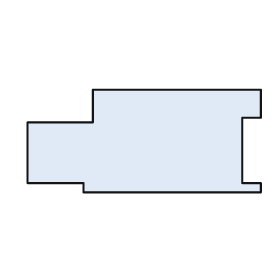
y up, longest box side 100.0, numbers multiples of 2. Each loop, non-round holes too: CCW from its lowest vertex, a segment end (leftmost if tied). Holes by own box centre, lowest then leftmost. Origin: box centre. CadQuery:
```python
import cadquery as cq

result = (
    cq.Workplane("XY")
    .moveTo(-26.0, -22.0)
    .lineTo(50.0, -22.0)
    .lineTo(50.0, -18.0)
    .lineTo(42.0, -18.0)
    .lineTo(42.0, 10.0)
    .lineTo(50.0, 10.0)
    .lineTo(50.0, 22.0)
    .lineTo(-22.0, 22.0)
    .lineTo(-22.0, 8.0)
    .lineTo(-50.0, 8.0)
    .lineTo(-50.0, -18.0)
    .lineTo(-26.0, -18.0)
    .close()
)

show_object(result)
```